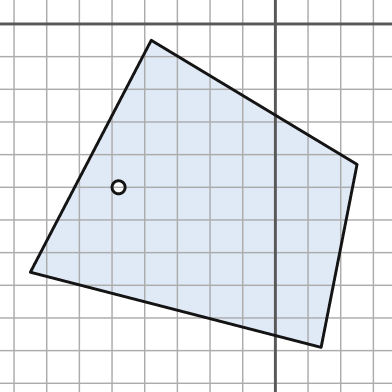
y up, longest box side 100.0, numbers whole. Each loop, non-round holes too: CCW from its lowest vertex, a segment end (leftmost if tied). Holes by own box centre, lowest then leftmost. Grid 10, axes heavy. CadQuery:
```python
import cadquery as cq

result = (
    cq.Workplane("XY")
    .moveTo(14.0, -99.0)
    .lineTo(25.0, -43.0)
    .lineTo(-38.0, -5.0)
    .lineTo(-75.0, -76.0)
    .close()
    .moveTo(-48.0, -50.0)
    .circle(2.0)
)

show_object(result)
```